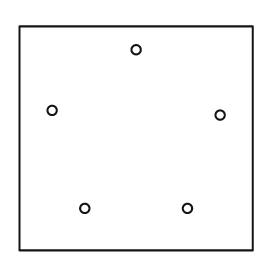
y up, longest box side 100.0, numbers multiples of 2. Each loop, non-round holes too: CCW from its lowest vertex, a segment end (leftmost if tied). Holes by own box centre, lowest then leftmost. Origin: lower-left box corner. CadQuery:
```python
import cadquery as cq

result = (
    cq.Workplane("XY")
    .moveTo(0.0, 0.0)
    .lineTo(100.0, 0.0)
    .lineTo(100.0, 96.0)
    .lineTo(0.0, 96.0)
    .close()
    .moveTo(28.0, 18.0)
    .circle(2.0)
    .moveTo(72.0, 18.0)
    .circle(2.0)
    .moveTo(86.0, 58.0)
    .circle(2.0)
    .moveTo(14.0, 60.0)
    .circle(2.0)
    .moveTo(50.0, 86.0)
    .circle(2.0)
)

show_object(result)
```